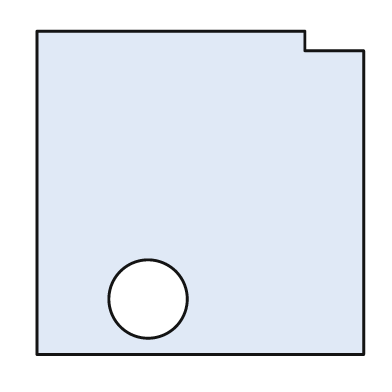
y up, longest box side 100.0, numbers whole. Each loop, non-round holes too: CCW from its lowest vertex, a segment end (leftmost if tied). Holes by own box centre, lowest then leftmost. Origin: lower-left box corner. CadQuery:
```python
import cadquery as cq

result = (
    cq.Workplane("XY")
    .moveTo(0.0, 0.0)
    .lineTo(100.0, 0.0)
    .lineTo(100.0, 93.0)
    .lineTo(82.0, 93.0)
    .lineTo(82.0, 99.0)
    .lineTo(0.0, 99.0)
    .close()
    .moveTo(34.0, 17.0)
    .circle(12.0)
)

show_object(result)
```